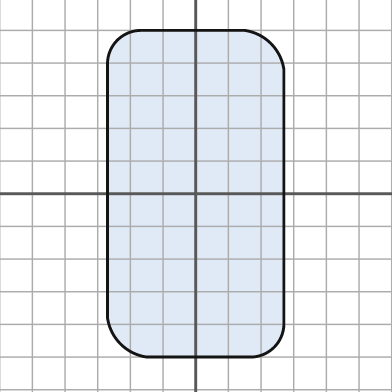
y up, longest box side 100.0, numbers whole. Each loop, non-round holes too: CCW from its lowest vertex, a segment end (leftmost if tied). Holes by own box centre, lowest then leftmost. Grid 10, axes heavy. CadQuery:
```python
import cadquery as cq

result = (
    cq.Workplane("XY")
    .moveTo(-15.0, -50.0)
    .lineTo(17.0, -50.0)
    .threePointArc((24.0, -47.0), (27.0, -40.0))
    .lineTo(27.0, 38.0)
    .threePointArc((23.0, 46.0), (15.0, 50.0))
    .lineTo(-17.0, 50.0)
    .threePointArc((-24.0, 47.0), (-27.0, 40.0))
    .lineTo(-27.0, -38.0)
    .threePointArc((-23.0, -46.0), (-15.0, -50.0))
    .close()
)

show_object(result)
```